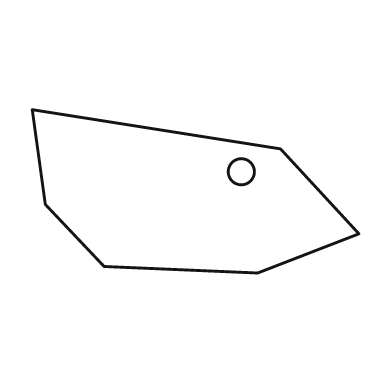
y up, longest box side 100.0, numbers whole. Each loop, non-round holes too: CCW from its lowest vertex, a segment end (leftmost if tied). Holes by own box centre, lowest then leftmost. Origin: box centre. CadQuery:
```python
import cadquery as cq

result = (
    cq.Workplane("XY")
    .moveTo(19.0, -25.0)
    .lineTo(50.0, -13.0)
    .lineTo(26.0, 13.0)
    .lineTo(-50.0, 25.0)
    .lineTo(-46.0, -4.0)
    .lineTo(-28.0, -23.0)
    .close()
    .moveTo(14.0, 6.0)
    .circle(4.0)
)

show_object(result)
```